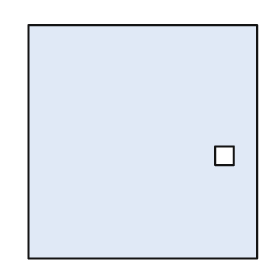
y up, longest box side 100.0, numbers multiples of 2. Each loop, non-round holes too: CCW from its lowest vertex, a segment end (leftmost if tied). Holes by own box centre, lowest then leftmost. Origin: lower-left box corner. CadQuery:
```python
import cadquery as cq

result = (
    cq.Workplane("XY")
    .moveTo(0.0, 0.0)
    .lineTo(98.0, 0.0)
    .lineTo(98.0, 100.0)
    .lineTo(0.0, 100.0)
    .close()
    .moveTo(80.0, 40.0)
    .lineTo(88.0, 40.0)
    .lineTo(88.0, 48.0)
    .lineTo(80.0, 48.0)
    .close()
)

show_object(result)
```